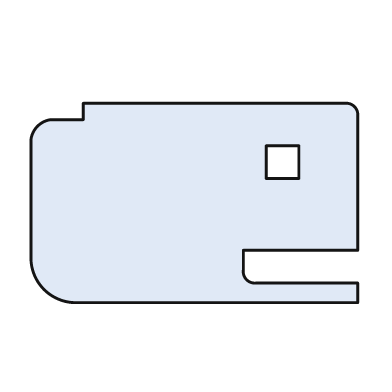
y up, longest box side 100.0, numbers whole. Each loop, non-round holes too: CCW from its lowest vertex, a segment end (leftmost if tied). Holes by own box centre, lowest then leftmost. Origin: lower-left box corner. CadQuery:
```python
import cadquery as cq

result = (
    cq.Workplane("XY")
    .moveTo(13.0, 0.0)
    .lineTo(100.0, 0.0)
    .lineTo(100.0, 6.0)
    .lineTo(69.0, 6.0)
    .threePointArc((66.0, 7.0), (65.0, 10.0))
    .lineTo(65.0, 16.0)
    .lineTo(100.0, 16.0)
    .lineTo(100.0, 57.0)
    .threePointArc((99.0, 60.0), (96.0, 61.0))
    .lineTo(16.0, 61.0)
    .lineTo(16.0, 56.0)
    .lineTo(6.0, 56.0)
    .threePointArc((2.0, 54.0), (0.0, 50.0))
    .lineTo(0.0, 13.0)
    .threePointArc((4.0, 4.0), (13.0, 0.0))
    .close()
    .moveTo(72.0, 38.0)
    .lineTo(82.0, 38.0)
    .lineTo(82.0, 48.0)
    .lineTo(72.0, 48.0)
    .close()
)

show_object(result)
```